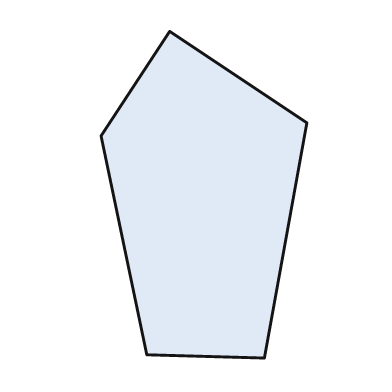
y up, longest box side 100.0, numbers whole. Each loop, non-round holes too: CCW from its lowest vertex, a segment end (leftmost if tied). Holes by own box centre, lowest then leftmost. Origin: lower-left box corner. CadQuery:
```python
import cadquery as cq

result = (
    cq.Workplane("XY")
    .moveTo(50.0, 0.0)
    .lineTo(63.0, 72.0)
    .lineTo(21.0, 100.0)
    .lineTo(0.0, 68.0)
    .lineTo(14.0, 1.0)
    .close()
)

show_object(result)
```